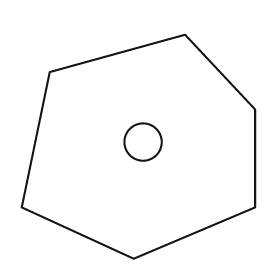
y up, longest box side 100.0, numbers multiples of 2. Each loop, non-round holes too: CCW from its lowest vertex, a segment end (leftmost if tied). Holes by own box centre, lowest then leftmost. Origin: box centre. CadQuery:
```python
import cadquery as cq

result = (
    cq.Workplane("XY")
    .moveTo(-2.0, -48.0)
    .lineTo(50.0, -26.0)
    .lineTo(50.0, 16.0)
    .lineTo(20.0, 48.0)
    .lineTo(-38.0, 32.0)
    .lineTo(-50.0, -26.0)
    .close()
    .moveTo(2.0, 2.0)
    .circle(8.0)
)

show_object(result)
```